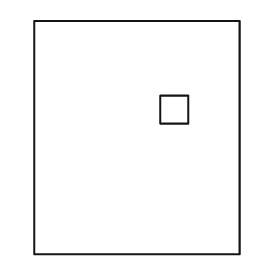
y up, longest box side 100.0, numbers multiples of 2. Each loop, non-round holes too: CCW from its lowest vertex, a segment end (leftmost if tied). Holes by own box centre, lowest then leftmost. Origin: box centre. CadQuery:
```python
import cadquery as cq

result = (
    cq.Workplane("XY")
    .moveTo(-44.0, -50.0)
    .lineTo(44.0, -50.0)
    .lineTo(44.0, 50.0)
    .lineTo(-44.0, 50.0)
    .close()
    .moveTo(10.0, 6.0)
    .lineTo(22.0, 6.0)
    .lineTo(22.0, 18.0)
    .lineTo(10.0, 18.0)
    .close()
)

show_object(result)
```